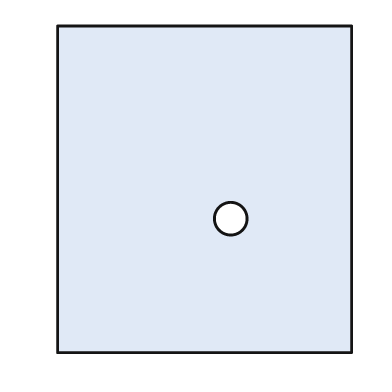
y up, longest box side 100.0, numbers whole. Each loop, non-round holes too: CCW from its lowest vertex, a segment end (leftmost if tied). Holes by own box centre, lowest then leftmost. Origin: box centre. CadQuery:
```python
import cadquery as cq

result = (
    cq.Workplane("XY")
    .moveTo(-45.0, -50.0)
    .lineTo(45.0, -50.0)
    .lineTo(45.0, 50.0)
    .lineTo(-45.0, 50.0)
    .close()
    .moveTo(8.0, -9.0)
    .circle(5.0)
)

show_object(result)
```